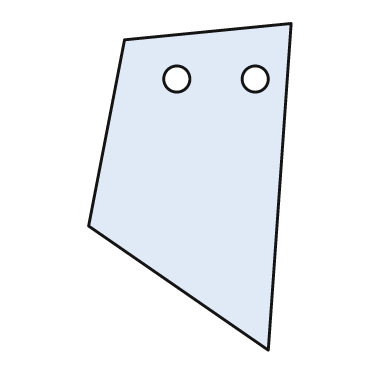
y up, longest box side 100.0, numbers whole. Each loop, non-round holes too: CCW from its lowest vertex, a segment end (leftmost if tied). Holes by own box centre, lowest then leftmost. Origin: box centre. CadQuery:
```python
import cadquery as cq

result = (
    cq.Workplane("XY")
    .moveTo(24.0, -50.0)
    .lineTo(31.0, 50.0)
    .lineTo(-20.0, 45.0)
    .lineTo(-31.0, -12.0)
    .close()
    .moveTo(-4.0, 33.0)
    .circle(4.0)
    .moveTo(20.0, 33.0)
    .circle(4.0)
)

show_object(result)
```